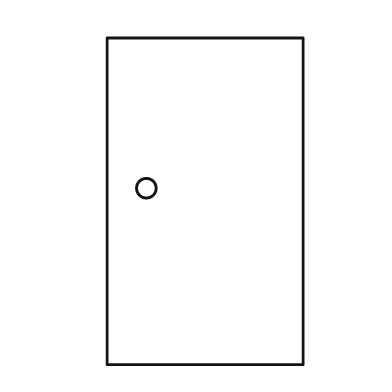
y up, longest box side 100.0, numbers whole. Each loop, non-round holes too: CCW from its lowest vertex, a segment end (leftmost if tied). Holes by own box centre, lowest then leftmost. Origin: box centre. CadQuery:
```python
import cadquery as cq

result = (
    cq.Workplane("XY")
    .moveTo(-30.0, -50.0)
    .lineTo(30.0, -50.0)
    .lineTo(30.0, 50.0)
    .lineTo(-30.0, 50.0)
    .close()
    .moveTo(-18.0, 4.0)
    .circle(3.0)
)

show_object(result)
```